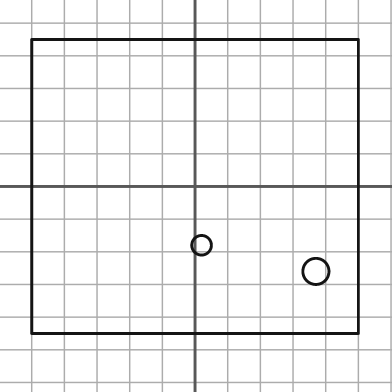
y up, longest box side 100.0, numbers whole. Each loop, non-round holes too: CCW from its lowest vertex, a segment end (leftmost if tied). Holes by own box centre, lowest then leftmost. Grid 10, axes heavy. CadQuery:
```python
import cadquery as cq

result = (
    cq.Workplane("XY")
    .moveTo(-50.0, -45.0)
    .lineTo(50.0, -45.0)
    .lineTo(50.0, 45.0)
    .lineTo(-50.0, 45.0)
    .close()
    .moveTo(37.0, -26.0)
    .circle(4.0)
    .moveTo(2.0, -18.0)
    .circle(3.0)
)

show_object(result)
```